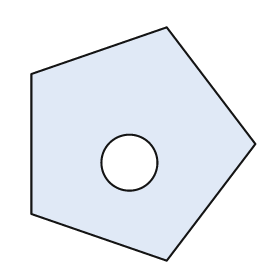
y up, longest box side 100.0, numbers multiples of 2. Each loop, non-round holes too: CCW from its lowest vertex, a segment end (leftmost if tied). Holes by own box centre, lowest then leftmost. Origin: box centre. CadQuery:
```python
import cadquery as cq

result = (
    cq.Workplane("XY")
    .moveTo(10.0, -50.0)
    .lineTo(48.0, 0.0)
    .lineTo(10.0, 50.0)
    .lineTo(-48.0, 30.0)
    .lineTo(-48.0, -30.0)
    .close()
    .moveTo(-6.0, -8.0)
    .circle(12.0)
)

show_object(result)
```